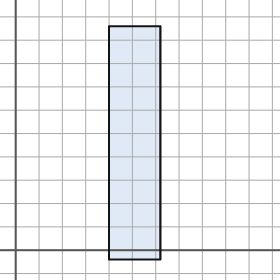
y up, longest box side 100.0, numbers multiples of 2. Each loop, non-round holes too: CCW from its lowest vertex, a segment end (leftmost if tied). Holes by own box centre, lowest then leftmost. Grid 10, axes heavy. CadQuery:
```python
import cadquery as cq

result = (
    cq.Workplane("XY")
    .moveTo(40.0, -4.0)
    .lineTo(62.0, -4.0)
    .lineTo(62.0, 96.0)
    .lineTo(40.0, 96.0)
    .close()
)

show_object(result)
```